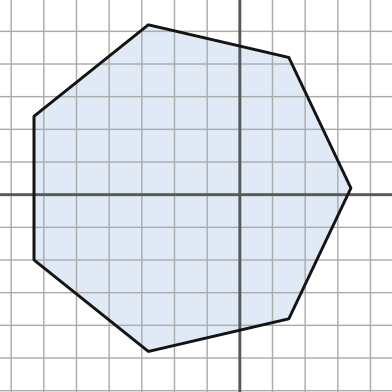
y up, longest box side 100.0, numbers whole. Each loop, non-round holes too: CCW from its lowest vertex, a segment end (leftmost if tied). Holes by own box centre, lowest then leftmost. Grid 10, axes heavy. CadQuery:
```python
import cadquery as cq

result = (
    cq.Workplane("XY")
    .moveTo(-28.0, -48.0)
    .lineTo(15.0, -38.0)
    .lineTo(34.0, 2.0)
    .lineTo(15.0, 42.0)
    .lineTo(-28.0, 52.0)
    .lineTo(-63.0, 24.0)
    .lineTo(-63.0, -20.0)
    .close()
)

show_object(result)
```